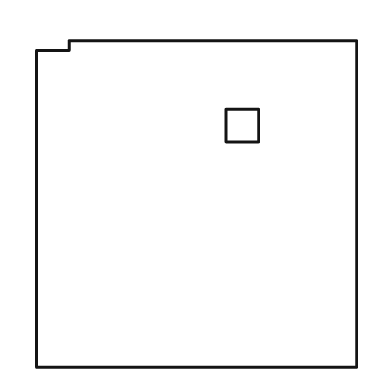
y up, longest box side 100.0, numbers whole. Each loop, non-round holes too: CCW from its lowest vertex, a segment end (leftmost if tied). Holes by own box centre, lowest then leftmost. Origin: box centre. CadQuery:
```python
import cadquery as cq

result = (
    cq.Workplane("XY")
    .moveTo(-49.0, -50.0)
    .lineTo(49.0, -50.0)
    .lineTo(49.0, 50.0)
    .lineTo(-39.0, 50.0)
    .lineTo(-39.0, 47.0)
    .lineTo(-49.0, 47.0)
    .close()
    .moveTo(9.0, 19.0)
    .lineTo(19.0, 19.0)
    .lineTo(19.0, 29.0)
    .lineTo(9.0, 29.0)
    .close()
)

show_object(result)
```